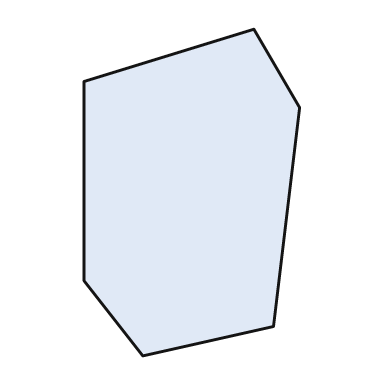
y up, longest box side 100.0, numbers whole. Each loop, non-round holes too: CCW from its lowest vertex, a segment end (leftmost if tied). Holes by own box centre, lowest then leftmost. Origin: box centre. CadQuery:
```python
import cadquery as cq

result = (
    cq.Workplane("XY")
    .moveTo(-15.0, -50.0)
    .lineTo(25.0, -41.0)
    .lineTo(33.0, 26.0)
    .lineTo(19.0, 50.0)
    .lineTo(-33.0, 34.0)
    .lineTo(-33.0, -27.0)
    .close()
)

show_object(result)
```